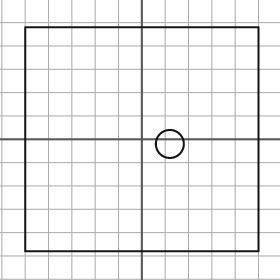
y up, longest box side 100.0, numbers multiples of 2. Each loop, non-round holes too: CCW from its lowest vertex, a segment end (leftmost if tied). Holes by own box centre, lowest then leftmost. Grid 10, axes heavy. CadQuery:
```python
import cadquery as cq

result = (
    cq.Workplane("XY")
    .moveTo(-50.0, -48.0)
    .lineTo(50.0, -48.0)
    .lineTo(50.0, 48.0)
    .lineTo(-50.0, 48.0)
    .close()
    .moveTo(12.0, -2.0)
    .circle(6.0)
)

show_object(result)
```